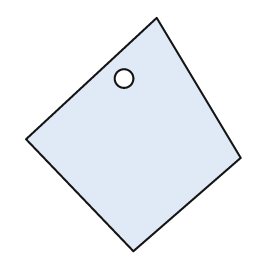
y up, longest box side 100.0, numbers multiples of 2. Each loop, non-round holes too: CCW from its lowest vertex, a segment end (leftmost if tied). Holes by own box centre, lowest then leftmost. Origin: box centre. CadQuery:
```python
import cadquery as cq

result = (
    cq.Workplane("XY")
    .moveTo(0.0, -50.0)
    .lineTo(46.0, -10.0)
    .lineTo(10.0, 50.0)
    .lineTo(-46.0, -2.0)
    .close()
    .moveTo(-4.0, 24.0)
    .circle(4.0)
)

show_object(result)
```